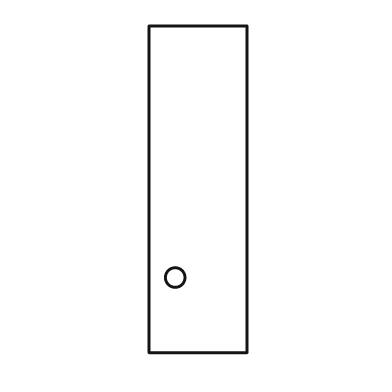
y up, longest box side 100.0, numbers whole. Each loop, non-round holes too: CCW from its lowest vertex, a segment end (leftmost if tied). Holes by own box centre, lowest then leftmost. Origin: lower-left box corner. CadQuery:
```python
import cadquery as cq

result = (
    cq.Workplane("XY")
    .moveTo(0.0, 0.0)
    .lineTo(30.0, 0.0)
    .lineTo(30.0, 100.0)
    .lineTo(0.0, 100.0)
    .close()
    .moveTo(8.0, 23.0)
    .circle(3.0)
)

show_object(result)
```